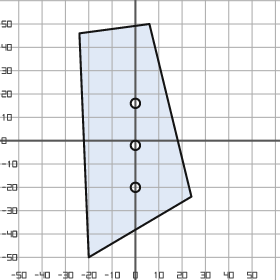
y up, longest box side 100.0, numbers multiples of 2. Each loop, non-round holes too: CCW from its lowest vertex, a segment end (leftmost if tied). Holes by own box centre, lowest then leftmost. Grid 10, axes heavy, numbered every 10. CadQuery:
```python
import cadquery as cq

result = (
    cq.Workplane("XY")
    .moveTo(-20.0, -50.0)
    .lineTo(24.0, -24.0)
    .lineTo(6.0, 50.0)
    .lineTo(-24.0, 46.0)
    .close()
    .moveTo(0.0, -20.0)
    .circle(2.0)
    .moveTo(0.0, -2.0)
    .circle(2.0)
    .moveTo(0.0, 16.0)
    .circle(2.0)
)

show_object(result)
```